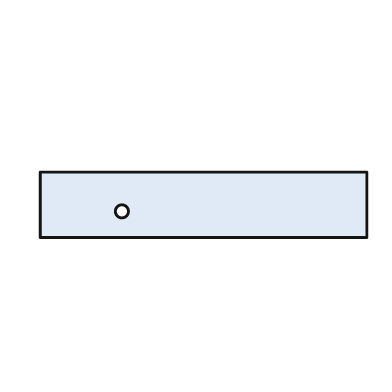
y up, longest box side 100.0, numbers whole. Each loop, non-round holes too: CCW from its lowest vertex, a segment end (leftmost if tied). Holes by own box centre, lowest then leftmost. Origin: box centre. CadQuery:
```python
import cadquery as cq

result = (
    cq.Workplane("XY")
    .moveTo(-50.0, -10.0)
    .lineTo(50.0, -10.0)
    .lineTo(50.0, 10.0)
    .lineTo(-50.0, 10.0)
    .close()
    .moveTo(-25.0, -2.0)
    .circle(2.0)
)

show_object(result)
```